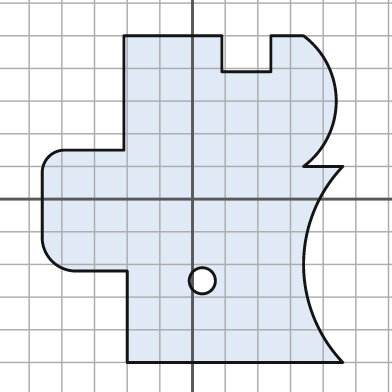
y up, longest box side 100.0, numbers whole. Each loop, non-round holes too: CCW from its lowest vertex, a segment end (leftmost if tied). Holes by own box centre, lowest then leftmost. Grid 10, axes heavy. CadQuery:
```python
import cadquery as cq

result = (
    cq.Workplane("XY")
    .moveTo(-20.0, -50.0)
    .lineTo(46.0, -50.0)
    .threePointArc((34.0, -20.0), (46.0, 10.0))
    .lineTo(34.0, 10.0)
    .threePointArc((44.0, 30.0), (34.0, 50.0))
    .lineTo(24.0, 50.0)
    .lineTo(24.0, 39.0)
    .lineTo(9.0, 39.0)
    .lineTo(9.0, 50.0)
    .lineTo(-21.0, 50.0)
    .lineTo(-21.0, 15.0)
    .lineTo(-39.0, 15.0)
    .threePointArc((-44.0, 13.0), (-46.0, 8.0))
    .lineTo(-46.0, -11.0)
    .threePointArc((-43.0, -19.0), (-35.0, -22.0))
    .lineTo(-20.0, -22.0)
    .close()
    .moveTo(3.0, -25.0)
    .circle(4.0)
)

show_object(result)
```